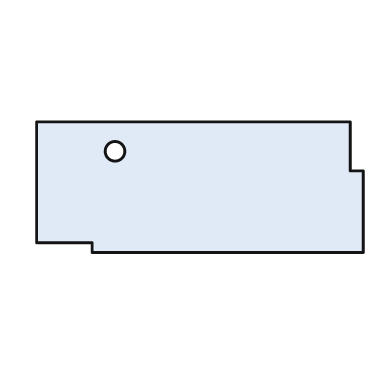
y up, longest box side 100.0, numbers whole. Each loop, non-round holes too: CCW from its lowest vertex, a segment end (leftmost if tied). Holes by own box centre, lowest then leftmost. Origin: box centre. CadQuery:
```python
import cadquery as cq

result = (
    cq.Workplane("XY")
    .moveTo(-33.0, -20.0)
    .lineTo(50.0, -20.0)
    .lineTo(50.0, 5.0)
    .lineTo(46.0, 5.0)
    .lineTo(46.0, 20.0)
    .lineTo(-50.0, 20.0)
    .lineTo(-50.0, -17.0)
    .lineTo(-33.0, -17.0)
    .close()
    .moveTo(-26.0, 11.0)
    .circle(3.0)
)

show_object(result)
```